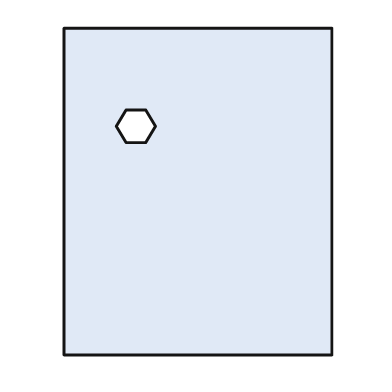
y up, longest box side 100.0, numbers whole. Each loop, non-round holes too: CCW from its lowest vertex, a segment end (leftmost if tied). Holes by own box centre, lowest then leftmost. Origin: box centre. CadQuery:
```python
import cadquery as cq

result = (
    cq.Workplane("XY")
    .moveTo(-41.0, -50.0)
    .lineTo(41.0, -50.0)
    .lineTo(41.0, 50.0)
    .lineTo(-41.0, 50.0)
    .close()
    .moveTo(-22.0, 15.0)
    .lineTo(-16.0, 15.0)
    .lineTo(-13.0, 20.0)
    .lineTo(-16.0, 25.0)
    .lineTo(-22.0, 25.0)
    .lineTo(-25.0, 20.0)
    .close()
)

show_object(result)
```